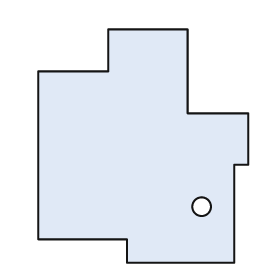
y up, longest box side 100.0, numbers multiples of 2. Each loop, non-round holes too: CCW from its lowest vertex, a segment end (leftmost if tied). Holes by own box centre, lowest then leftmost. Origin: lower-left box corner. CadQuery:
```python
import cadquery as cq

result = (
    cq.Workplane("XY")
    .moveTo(38.0, 0.0)
    .lineTo(84.0, 0.0)
    .lineTo(84.0, 42.0)
    .lineTo(90.0, 42.0)
    .lineTo(90.0, 64.0)
    .lineTo(64.0, 64.0)
    .lineTo(64.0, 100.0)
    .lineTo(30.0, 100.0)
    .lineTo(30.0, 82.0)
    .lineTo(0.0, 82.0)
    .lineTo(0.0, 10.0)
    .lineTo(38.0, 10.0)
    .close()
    .moveTo(70.0, 24.0)
    .circle(4.0)
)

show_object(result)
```